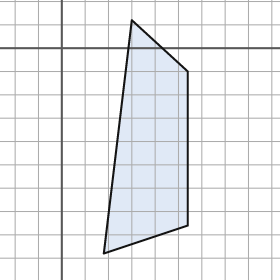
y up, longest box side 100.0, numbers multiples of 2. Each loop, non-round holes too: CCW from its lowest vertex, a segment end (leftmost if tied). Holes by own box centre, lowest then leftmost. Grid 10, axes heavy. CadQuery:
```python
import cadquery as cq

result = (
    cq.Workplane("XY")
    .moveTo(18.0, -88.0)
    .lineTo(54.0, -76.0)
    .lineTo(54.0, -10.0)
    .lineTo(30.0, 12.0)
    .close()
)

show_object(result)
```